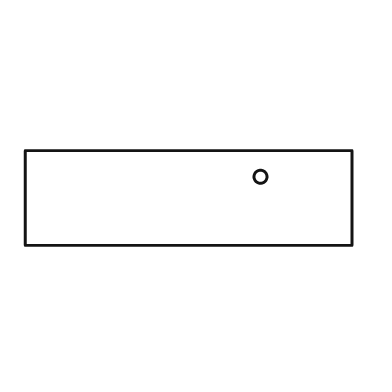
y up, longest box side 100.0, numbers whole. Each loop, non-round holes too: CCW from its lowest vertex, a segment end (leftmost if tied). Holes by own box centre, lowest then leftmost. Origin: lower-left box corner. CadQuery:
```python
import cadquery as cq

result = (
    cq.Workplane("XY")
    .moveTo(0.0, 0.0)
    .lineTo(100.0, 0.0)
    .lineTo(100.0, 29.0)
    .lineTo(0.0, 29.0)
    .close()
    .moveTo(72.0, 21.0)
    .circle(2.0)
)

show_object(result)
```